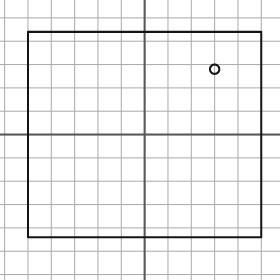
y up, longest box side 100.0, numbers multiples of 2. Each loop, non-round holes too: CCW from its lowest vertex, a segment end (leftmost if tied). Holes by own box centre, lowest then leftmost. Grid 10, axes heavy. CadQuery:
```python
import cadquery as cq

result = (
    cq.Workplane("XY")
    .moveTo(-50.0, -44.0)
    .lineTo(50.0, -44.0)
    .lineTo(50.0, 44.0)
    .lineTo(-50.0, 44.0)
    .close()
    .moveTo(30.0, 28.0)
    .circle(2.0)
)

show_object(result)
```